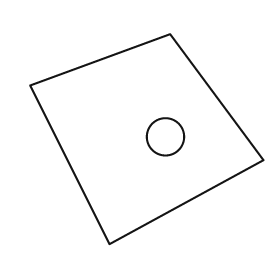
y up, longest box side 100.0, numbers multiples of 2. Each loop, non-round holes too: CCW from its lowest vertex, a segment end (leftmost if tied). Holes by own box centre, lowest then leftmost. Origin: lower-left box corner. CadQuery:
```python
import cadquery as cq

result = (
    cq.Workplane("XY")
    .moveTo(34.0, 0.0)
    .lineTo(100.0, 36.0)
    .lineTo(60.0, 90.0)
    .lineTo(0.0, 68.0)
    .close()
    .moveTo(58.0, 46.0)
    .circle(8.0)
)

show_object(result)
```